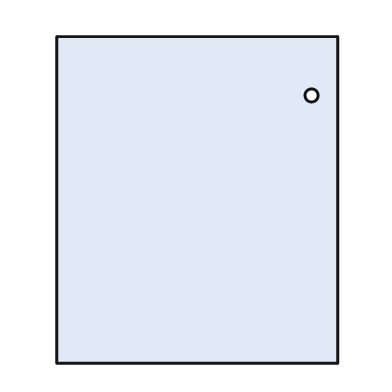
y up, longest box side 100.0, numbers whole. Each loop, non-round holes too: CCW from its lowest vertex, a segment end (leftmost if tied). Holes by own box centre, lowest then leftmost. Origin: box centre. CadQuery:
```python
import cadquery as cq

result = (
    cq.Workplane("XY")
    .moveTo(-43.0, -50.0)
    .lineTo(43.0, -50.0)
    .lineTo(43.0, 50.0)
    .lineTo(-43.0, 50.0)
    .close()
    .moveTo(35.0, 32.0)
    .circle(2.0)
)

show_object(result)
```